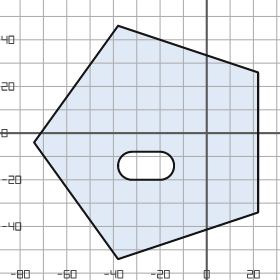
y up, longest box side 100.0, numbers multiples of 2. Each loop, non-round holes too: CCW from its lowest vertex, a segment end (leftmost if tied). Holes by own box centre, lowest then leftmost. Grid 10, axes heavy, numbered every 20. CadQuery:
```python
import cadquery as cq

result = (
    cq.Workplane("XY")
    .moveTo(-38.0, -54.0)
    .lineTo(22.0, -34.0)
    .lineTo(22.0, 26.0)
    .lineTo(-38.0, 46.0)
    .lineTo(-74.0, -4.0)
    .close()
    .moveTo(-32.0, -20.0)
    .lineTo(-20.0, -20.0)
    .threePointArc((-14.0, -14.0), (-20.0, -8.0))
    .lineTo(-32.0, -8.0)
    .threePointArc((-38.0, -14.0), (-32.0, -20.0))
    .close()
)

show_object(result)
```